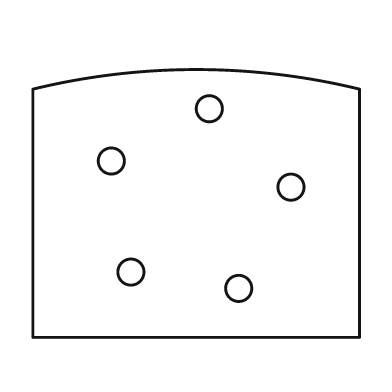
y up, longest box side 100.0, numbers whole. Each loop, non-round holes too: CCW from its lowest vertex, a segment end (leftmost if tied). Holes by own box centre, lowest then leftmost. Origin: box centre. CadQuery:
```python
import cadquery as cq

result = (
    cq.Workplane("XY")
    .moveTo(-50.0, -41.0)
    .lineTo(50.0, -41.0)
    .lineTo(50.0, 35.0)
    .threePointArc((0.0, 41.0), (-50.0, 35.0))
    .close()
    .moveTo(13.0, -26.0)
    .circle(4.0)
    .moveTo(-20.0, -21.0)
    .circle(4.0)
    .moveTo(29.0, 5.0)
    .circle(4.0)
    .moveTo(-26.0, 13.0)
    .circle(4.0)
    .moveTo(4.0, 29.0)
    .circle(4.0)
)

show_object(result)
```